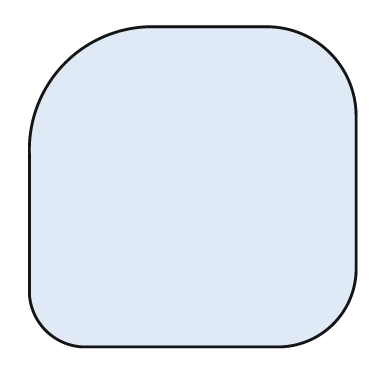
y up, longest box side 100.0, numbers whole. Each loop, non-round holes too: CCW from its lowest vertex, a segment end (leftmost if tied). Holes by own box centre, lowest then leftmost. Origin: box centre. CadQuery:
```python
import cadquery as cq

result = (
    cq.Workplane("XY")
    .moveTo(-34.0, -49.0)
    .lineTo(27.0, -49.0)
    .threePointArc((43.0, -42.0), (50.0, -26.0))
    .lineTo(50.0, 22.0)
    .threePointArc((42.0, 41.0), (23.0, 49.0))
    .lineTo(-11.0, 49.0)
    .threePointArc((-39.0, 38.0), (-50.0, 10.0))
    .lineTo(-50.0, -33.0)
    .threePointArc((-45.0, -44.0), (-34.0, -49.0))
    .close()
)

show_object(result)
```